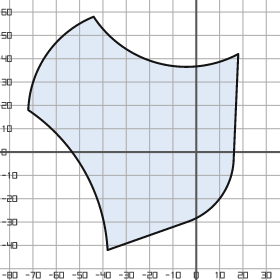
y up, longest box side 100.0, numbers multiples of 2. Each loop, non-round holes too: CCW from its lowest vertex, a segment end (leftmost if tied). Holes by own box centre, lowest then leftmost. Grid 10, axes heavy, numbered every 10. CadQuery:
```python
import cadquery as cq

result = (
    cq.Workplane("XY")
    .moveTo(-38.0, -42.0)
    .lineTo(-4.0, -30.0)
    .threePointArc((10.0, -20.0), (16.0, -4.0))
    .lineTo(18.0, 42.0)
    .threePointArc((-16.0, 38.0), (-44.0, 58.0))
    .threePointArc((-64.0, 42.0), (-72.0, 18.0))
    .threePointArc((-48.0, -8.0), (-38.0, -42.0))
    .close()
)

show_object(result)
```